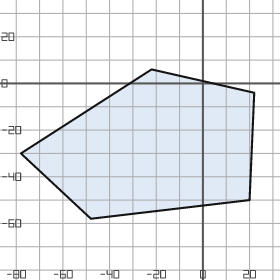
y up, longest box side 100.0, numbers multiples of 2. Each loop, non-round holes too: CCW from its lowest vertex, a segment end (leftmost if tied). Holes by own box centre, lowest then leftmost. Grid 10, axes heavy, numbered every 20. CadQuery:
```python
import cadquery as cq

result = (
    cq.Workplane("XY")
    .moveTo(-48.0, -58.0)
    .lineTo(20.0, -50.0)
    .lineTo(22.0, -4.0)
    .lineTo(-22.0, 6.0)
    .lineTo(-78.0, -30.0)
    .close()
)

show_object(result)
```